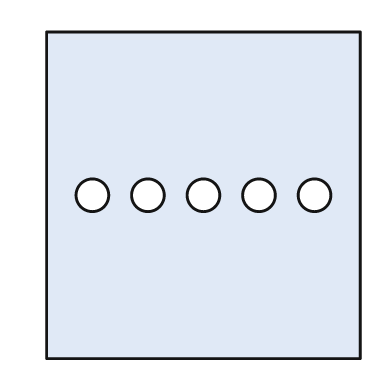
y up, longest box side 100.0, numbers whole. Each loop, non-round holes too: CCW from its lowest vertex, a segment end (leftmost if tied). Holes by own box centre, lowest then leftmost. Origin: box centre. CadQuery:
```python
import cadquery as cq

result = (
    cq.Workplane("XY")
    .moveTo(-48.0, -50.0)
    .lineTo(48.0, -50.0)
    .lineTo(48.0, 50.0)
    .lineTo(-48.0, 50.0)
    .close()
    .moveTo(-34.0, 0.0)
    .circle(5.0)
    .moveTo(-17.0, 0.0)
    .circle(5.0)
    .moveTo(0.0, 0.0)
    .circle(5.0)
    .moveTo(17.0, 0.0)
    .circle(5.0)
    .moveTo(34.0, 0.0)
    .circle(5.0)
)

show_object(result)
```